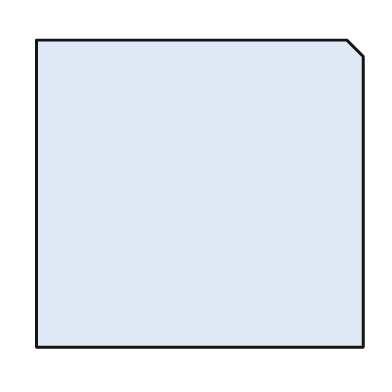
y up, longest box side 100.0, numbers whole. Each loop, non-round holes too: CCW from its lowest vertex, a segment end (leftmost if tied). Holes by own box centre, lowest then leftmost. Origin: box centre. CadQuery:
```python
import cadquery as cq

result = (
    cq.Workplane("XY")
    .moveTo(-50.0, -47.0)
    .lineTo(50.0, -47.0)
    .lineTo(50.0, 42.0)
    .lineTo(45.0, 47.0)
    .lineTo(-50.0, 47.0)
    .close()
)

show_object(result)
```